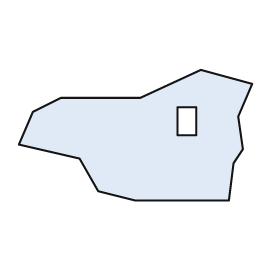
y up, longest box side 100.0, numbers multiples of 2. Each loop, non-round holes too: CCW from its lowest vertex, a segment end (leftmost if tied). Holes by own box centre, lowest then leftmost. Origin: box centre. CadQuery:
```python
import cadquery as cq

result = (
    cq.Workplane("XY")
    .moveTo(0.0, -28.0)
    .lineTo(40.0, -28.0)
    .lineTo(42.0, -12.0)
    .lineTo(46.0, -6.0)
    .lineTo(44.0, 8.0)
    .lineTo(50.0, 22.0)
    .lineTo(28.0, 28.0)
    .lineTo(2.0, 16.0)
    .lineTo(-32.0, 16.0)
    .lineTo(-44.0, 10.0)
    .lineTo(-50.0, -4.0)
    .lineTo(-24.0, -10.0)
    .lineTo(-16.0, -24.0)
    .close()
    .moveTo(18.0, 0.0)
    .lineTo(26.0, 0.0)
    .lineTo(26.0, 12.0)
    .lineTo(18.0, 12.0)
    .close()
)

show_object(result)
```